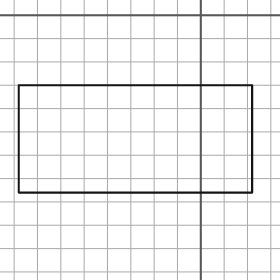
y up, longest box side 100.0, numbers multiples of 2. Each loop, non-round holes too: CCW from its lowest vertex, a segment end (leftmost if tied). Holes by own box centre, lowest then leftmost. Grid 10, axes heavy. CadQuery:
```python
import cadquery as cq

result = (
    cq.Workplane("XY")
    .moveTo(-78.0, -76.0)
    .lineTo(22.0, -76.0)
    .lineTo(22.0, -30.0)
    .lineTo(-78.0, -30.0)
    .close()
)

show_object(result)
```